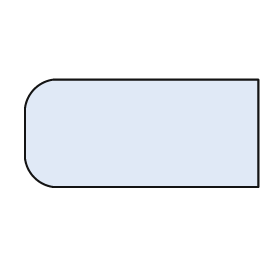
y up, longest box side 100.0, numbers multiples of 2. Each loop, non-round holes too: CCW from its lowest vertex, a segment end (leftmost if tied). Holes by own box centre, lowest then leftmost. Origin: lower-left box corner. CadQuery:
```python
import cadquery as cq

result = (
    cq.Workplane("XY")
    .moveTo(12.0, 0.0)
    .lineTo(100.0, 0.0)
    .lineTo(100.0, 46.0)
    .lineTo(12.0, 46.0)
    .threePointArc((4.0, 42.0), (0.0, 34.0))
    .lineTo(0.0, 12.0)
    .threePointArc((4.0, 4.0), (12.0, 0.0))
    .close()
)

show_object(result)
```